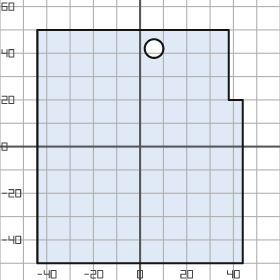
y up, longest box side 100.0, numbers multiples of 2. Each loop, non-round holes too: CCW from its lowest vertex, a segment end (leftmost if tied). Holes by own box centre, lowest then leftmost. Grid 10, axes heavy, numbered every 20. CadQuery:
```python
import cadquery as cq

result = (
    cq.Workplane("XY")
    .moveTo(-44.0, -50.0)
    .lineTo(44.0, -50.0)
    .lineTo(44.0, 20.0)
    .lineTo(38.0, 20.0)
    .lineTo(38.0, 50.0)
    .lineTo(-44.0, 50.0)
    .close()
    .moveTo(6.0, 42.0)
    .circle(4.0)
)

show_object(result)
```